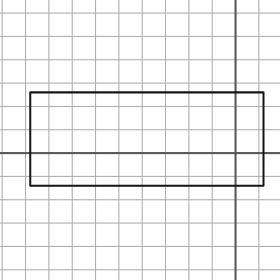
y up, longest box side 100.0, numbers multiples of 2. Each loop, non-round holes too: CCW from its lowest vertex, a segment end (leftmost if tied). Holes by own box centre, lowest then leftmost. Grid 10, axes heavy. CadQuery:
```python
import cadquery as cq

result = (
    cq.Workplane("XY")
    .moveTo(-88.0, -14.0)
    .lineTo(12.0, -14.0)
    .lineTo(12.0, 26.0)
    .lineTo(-88.0, 26.0)
    .close()
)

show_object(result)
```